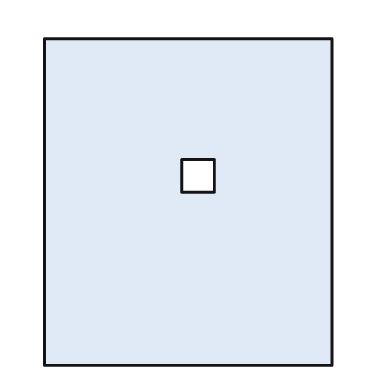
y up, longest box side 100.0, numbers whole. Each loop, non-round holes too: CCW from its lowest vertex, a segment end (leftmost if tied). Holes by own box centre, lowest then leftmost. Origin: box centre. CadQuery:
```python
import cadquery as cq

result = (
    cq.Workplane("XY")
    .moveTo(-44.0, -50.0)
    .lineTo(44.0, -50.0)
    .lineTo(44.0, 50.0)
    .lineTo(-44.0, 50.0)
    .close()
    .moveTo(-2.0, 3.0)
    .lineTo(8.0, 3.0)
    .lineTo(8.0, 13.0)
    .lineTo(-2.0, 13.0)
    .close()
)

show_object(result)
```